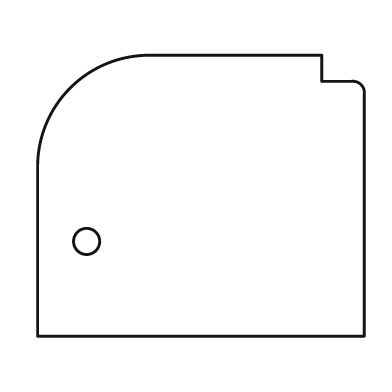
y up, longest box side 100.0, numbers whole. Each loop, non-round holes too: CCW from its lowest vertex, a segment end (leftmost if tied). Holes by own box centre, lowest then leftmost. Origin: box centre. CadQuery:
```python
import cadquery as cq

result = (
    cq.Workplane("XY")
    .moveTo(-50.0, -43.0)
    .lineTo(50.0, -43.0)
    .lineTo(50.0, 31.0)
    .threePointArc((49.0, 34.0), (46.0, 35.0))
    .lineTo(37.0, 35.0)
    .lineTo(37.0, 43.0)
    .lineTo(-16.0, 43.0)
    .threePointArc((-40.0, 33.0), (-50.0, 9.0))
    .close()
    .moveTo(-35.0, -14.0)
    .circle(4.0)
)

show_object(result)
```